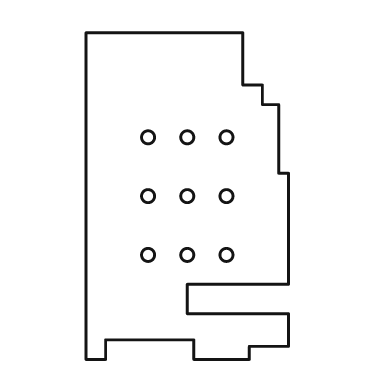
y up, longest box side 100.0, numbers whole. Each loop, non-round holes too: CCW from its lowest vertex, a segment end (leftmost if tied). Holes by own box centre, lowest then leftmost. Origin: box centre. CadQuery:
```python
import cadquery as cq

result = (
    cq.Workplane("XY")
    .moveTo(-31.0, -50.0)
    .lineTo(-25.0, -50.0)
    .lineTo(-25.0, -44.0)
    .lineTo(2.0, -44.0)
    .lineTo(2.0, -50.0)
    .lineTo(19.0, -50.0)
    .lineTo(19.0, -46.0)
    .lineTo(31.0, -46.0)
    .lineTo(31.0, -36.0)
    .lineTo(0.0, -36.0)
    .lineTo(0.0, -27.0)
    .lineTo(31.0, -27.0)
    .lineTo(31.0, 7.0)
    .lineTo(28.0, 7.0)
    .lineTo(28.0, 28.0)
    .lineTo(23.0, 28.0)
    .lineTo(23.0, 34.0)
    .lineTo(17.0, 34.0)
    .lineTo(17.0, 50.0)
    .lineTo(-31.0, 50.0)
    .close()
    .moveTo(-12.0, -18.0)
    .circle(2.0)
    .moveTo(0.0, -18.0)
    .circle(2.0)
    .moveTo(12.0, -18.0)
    .circle(2.0)
    .moveTo(-12.0, 0.0)
    .circle(2.0)
    .moveTo(0.0, 0.0)
    .circle(2.0)
    .moveTo(12.0, 0.0)
    .circle(2.0)
    .moveTo(-12.0, 18.0)
    .circle(2.0)
    .moveTo(0.0, 18.0)
    .circle(2.0)
    .moveTo(12.0, 18.0)
    .circle(2.0)
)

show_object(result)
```